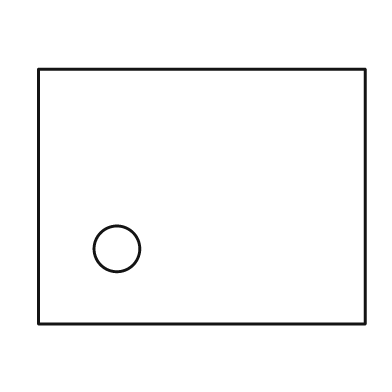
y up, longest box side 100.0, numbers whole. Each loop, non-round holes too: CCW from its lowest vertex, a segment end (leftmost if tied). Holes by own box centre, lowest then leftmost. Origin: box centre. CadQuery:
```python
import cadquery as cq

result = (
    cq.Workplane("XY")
    .moveTo(-50.0, -39.0)
    .lineTo(50.0, -39.0)
    .lineTo(50.0, 39.0)
    .lineTo(-50.0, 39.0)
    .close()
    .moveTo(-26.0, -16.0)
    .circle(7.0)
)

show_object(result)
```